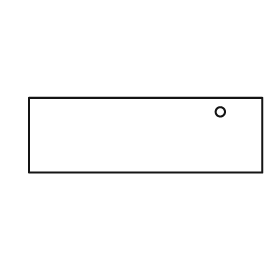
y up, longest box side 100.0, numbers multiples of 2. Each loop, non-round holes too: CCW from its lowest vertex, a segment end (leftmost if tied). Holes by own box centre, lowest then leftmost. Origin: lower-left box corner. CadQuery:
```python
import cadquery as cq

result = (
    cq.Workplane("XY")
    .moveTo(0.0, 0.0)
    .lineTo(100.0, 0.0)
    .lineTo(100.0, 32.0)
    .lineTo(0.0, 32.0)
    .close()
    .moveTo(82.0, 26.0)
    .circle(2.0)
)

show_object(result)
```